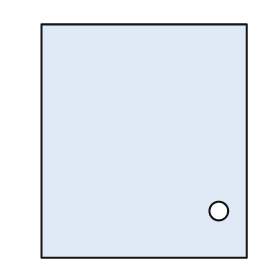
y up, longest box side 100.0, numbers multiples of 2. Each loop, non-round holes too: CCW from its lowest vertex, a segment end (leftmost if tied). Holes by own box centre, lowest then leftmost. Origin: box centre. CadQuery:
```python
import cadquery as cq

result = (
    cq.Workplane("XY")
    .moveTo(-44.0, -50.0)
    .lineTo(44.0, -50.0)
    .lineTo(44.0, 50.0)
    .lineTo(-44.0, 50.0)
    .close()
    .moveTo(32.0, -30.0)
    .circle(4.0)
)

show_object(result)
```